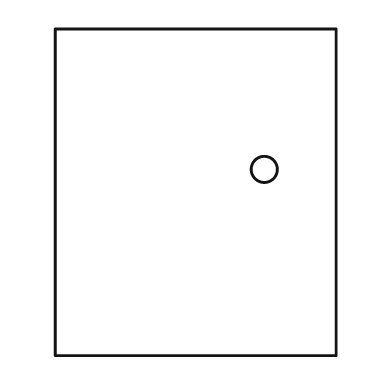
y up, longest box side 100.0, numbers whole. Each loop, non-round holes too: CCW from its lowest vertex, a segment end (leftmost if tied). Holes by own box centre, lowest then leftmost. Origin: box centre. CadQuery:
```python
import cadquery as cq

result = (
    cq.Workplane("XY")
    .moveTo(-43.0, -50.0)
    .lineTo(43.0, -50.0)
    .lineTo(43.0, 50.0)
    .lineTo(-43.0, 50.0)
    .close()
    .moveTo(21.0, 7.0)
    .circle(4.0)
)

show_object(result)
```